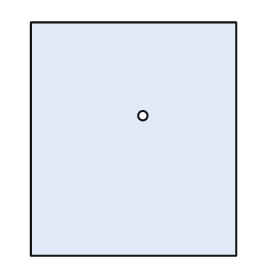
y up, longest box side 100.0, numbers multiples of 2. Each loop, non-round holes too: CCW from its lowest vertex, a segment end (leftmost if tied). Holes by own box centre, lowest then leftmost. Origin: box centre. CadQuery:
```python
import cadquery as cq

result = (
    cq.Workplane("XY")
    .moveTo(-44.0, -50.0)
    .lineTo(44.0, -50.0)
    .lineTo(44.0, 50.0)
    .lineTo(-44.0, 50.0)
    .close()
    .moveTo(4.0, 10.0)
    .circle(2.0)
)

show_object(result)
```